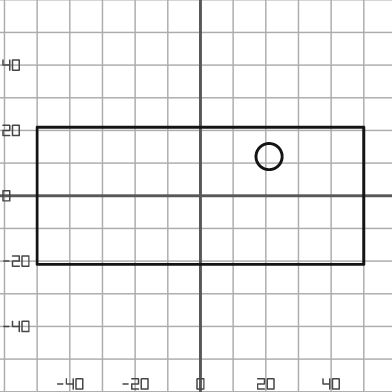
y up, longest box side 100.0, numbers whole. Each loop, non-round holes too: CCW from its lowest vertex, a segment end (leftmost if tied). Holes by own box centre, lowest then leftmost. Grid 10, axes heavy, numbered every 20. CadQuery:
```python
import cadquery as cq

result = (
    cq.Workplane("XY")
    .moveTo(-50.0, -21.0)
    .lineTo(50.0, -21.0)
    .lineTo(50.0, 21.0)
    .lineTo(-50.0, 21.0)
    .close()
    .moveTo(21.0, 12.0)
    .circle(4.0)
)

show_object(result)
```